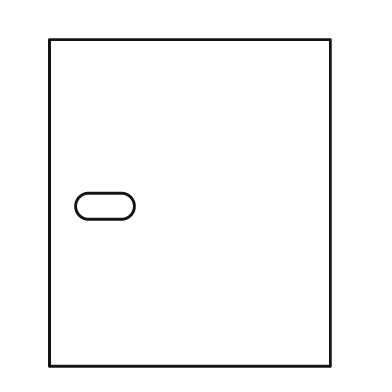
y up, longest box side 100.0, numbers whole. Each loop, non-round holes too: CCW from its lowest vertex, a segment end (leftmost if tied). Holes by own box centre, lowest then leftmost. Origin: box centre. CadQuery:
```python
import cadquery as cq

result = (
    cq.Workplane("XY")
    .moveTo(-43.0, -50.0)
    .lineTo(43.0, -50.0)
    .lineTo(43.0, 50.0)
    .lineTo(-43.0, 50.0)
    .close()
    .moveTo(-31.0, -5.0)
    .lineTo(-21.0, -5.0)
    .threePointArc((-17.0, -1.0), (-21.0, 3.0))
    .lineTo(-31.0, 3.0)
    .threePointArc((-35.0, -1.0), (-31.0, -5.0))
    .close()
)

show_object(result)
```